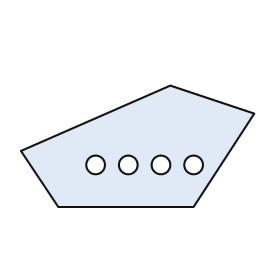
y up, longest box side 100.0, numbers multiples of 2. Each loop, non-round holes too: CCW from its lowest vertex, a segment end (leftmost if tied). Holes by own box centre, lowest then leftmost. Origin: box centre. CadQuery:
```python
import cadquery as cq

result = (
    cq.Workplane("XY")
    .moveTo(-34.0, -26.0)
    .lineTo(24.0, -26.0)
    .lineTo(50.0, 14.0)
    .lineTo(14.0, 26.0)
    .lineTo(-50.0, -2.0)
    .close()
    .moveTo(-18.0, -8.0)
    .circle(4.0)
    .moveTo(-4.0, -8.0)
    .circle(4.0)
    .moveTo(10.0, -8.0)
    .circle(4.0)
    .moveTo(24.0, -8.0)
    .circle(4.0)
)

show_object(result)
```